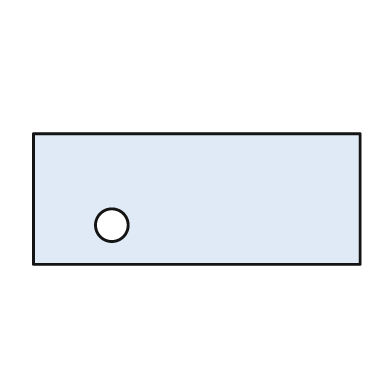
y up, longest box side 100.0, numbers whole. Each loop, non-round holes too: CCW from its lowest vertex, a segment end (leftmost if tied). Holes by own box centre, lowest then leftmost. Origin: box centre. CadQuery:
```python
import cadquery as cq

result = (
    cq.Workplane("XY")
    .moveTo(-50.0, -20.0)
    .lineTo(50.0, -20.0)
    .lineTo(50.0, 20.0)
    .lineTo(-50.0, 20.0)
    .close()
    .moveTo(-26.0, -8.0)
    .circle(5.0)
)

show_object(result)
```